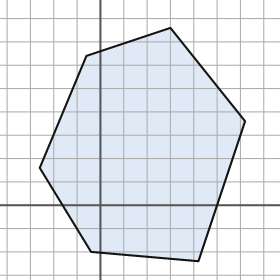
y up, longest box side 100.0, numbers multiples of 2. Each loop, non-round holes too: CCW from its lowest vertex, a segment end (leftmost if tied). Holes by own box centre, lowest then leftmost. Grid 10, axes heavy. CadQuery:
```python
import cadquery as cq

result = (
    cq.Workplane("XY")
    .moveTo(42.0, -24.0)
    .lineTo(62.0, 36.0)
    .lineTo(30.0, 76.0)
    .lineTo(-6.0, 64.0)
    .lineTo(-26.0, 16.0)
    .lineTo(-4.0, -20.0)
    .close()
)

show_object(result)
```